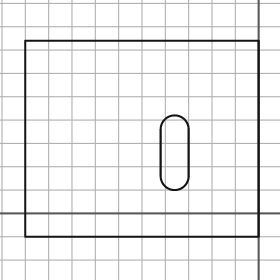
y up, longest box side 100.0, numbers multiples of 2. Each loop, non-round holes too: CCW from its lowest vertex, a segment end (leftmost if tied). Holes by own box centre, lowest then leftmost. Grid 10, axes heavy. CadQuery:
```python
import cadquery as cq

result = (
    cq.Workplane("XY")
    .moveTo(-100.0, -10.0)
    .lineTo(0.0, -10.0)
    .lineTo(0.0, 74.0)
    .lineTo(-100.0, 74.0)
    .close()
    .moveTo(-42.0, 16.0)
    .threePointArc((-36.0, 10.0), (-30.0, 16.0))
    .lineTo(-30.0, 36.0)
    .threePointArc((-36.0, 42.0), (-42.0, 36.0))
    .close()
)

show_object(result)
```